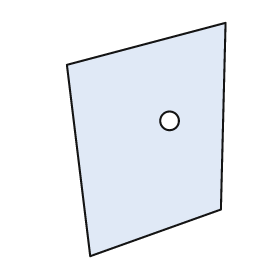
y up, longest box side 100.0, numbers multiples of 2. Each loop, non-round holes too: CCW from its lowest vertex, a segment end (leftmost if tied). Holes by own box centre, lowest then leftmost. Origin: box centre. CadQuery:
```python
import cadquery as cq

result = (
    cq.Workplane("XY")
    .moveTo(-24.0, -50.0)
    .lineTo(32.0, -30.0)
    .lineTo(34.0, 50.0)
    .lineTo(-34.0, 32.0)
    .close()
    .moveTo(10.0, 8.0)
    .circle(4.0)
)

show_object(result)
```